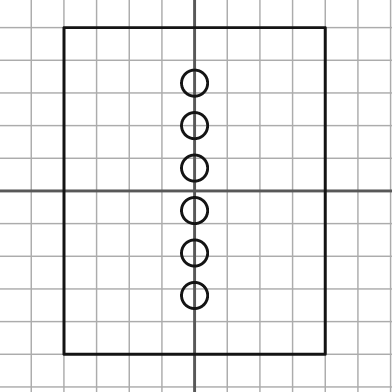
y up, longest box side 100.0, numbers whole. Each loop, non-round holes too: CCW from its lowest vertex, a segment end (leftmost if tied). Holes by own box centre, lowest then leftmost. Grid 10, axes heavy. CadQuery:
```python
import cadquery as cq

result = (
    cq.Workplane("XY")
    .moveTo(-40.0, -50.0)
    .lineTo(40.0, -50.0)
    .lineTo(40.0, 50.0)
    .lineTo(-40.0, 50.0)
    .close()
    .moveTo(0.0, -32.0)
    .circle(4.0)
    .moveTo(0.0, -19.0)
    .circle(4.0)
    .moveTo(0.0, -6.0)
    .circle(4.0)
    .moveTo(0.0, 7.0)
    .circle(4.0)
    .moveTo(0.0, 20.0)
    .circle(4.0)
    .moveTo(0.0, 33.0)
    .circle(4.0)
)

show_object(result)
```